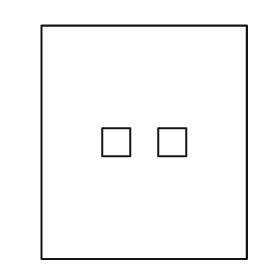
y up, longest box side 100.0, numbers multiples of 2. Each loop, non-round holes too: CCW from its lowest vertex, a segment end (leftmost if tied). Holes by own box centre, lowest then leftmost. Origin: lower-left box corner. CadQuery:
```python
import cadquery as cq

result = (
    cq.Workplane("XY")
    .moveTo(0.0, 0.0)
    .lineTo(88.0, 0.0)
    .lineTo(88.0, 100.0)
    .lineTo(0.0, 100.0)
    .close()
    .moveTo(26.0, 44.0)
    .lineTo(38.0, 44.0)
    .lineTo(38.0, 56.0)
    .lineTo(26.0, 56.0)
    .close()
    .moveTo(50.0, 44.0)
    .lineTo(62.0, 44.0)
    .lineTo(62.0, 56.0)
    .lineTo(50.0, 56.0)
    .close()
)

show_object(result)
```